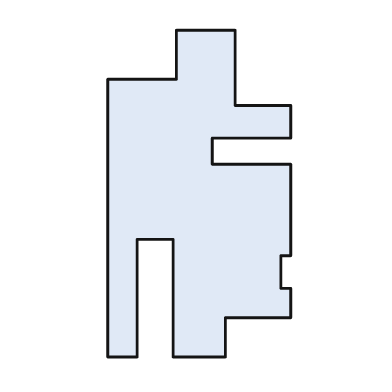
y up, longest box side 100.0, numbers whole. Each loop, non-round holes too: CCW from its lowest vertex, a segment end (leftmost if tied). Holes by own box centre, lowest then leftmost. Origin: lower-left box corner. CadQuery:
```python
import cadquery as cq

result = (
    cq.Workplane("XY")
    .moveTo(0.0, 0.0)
    .lineTo(9.0, 0.0)
    .lineTo(9.0, 36.0)
    .lineTo(20.0, 36.0)
    .lineTo(20.0, 0.0)
    .lineTo(36.0, 0.0)
    .lineTo(36.0, 12.0)
    .lineTo(56.0, 12.0)
    .lineTo(56.0, 21.0)
    .lineTo(53.0, 21.0)
    .lineTo(53.0, 31.0)
    .lineTo(56.0, 31.0)
    .lineTo(56.0, 59.0)
    .lineTo(32.0, 59.0)
    .lineTo(32.0, 67.0)
    .lineTo(56.0, 67.0)
    .lineTo(56.0, 77.0)
    .lineTo(39.0, 77.0)
    .lineTo(39.0, 100.0)
    .lineTo(21.0, 100.0)
    .lineTo(21.0, 85.0)
    .lineTo(0.0, 85.0)
    .close()
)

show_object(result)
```